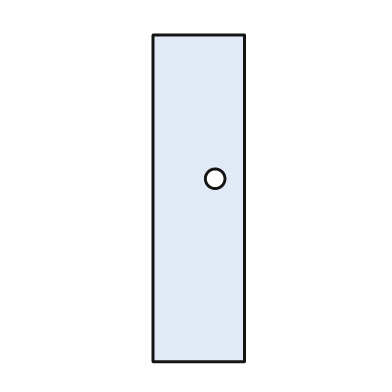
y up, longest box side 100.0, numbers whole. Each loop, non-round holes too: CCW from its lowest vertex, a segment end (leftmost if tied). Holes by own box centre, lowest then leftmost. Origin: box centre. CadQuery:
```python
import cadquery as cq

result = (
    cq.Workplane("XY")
    .moveTo(-14.0, -50.0)
    .lineTo(14.0, -50.0)
    .lineTo(14.0, 50.0)
    .lineTo(-14.0, 50.0)
    .close()
    .moveTo(5.0, 6.0)
    .circle(3.0)
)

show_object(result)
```